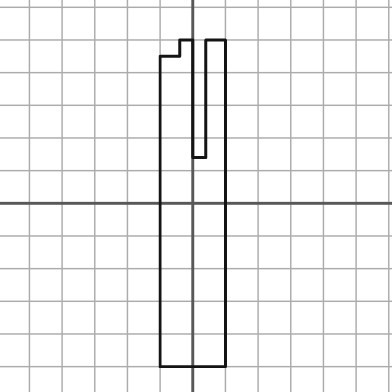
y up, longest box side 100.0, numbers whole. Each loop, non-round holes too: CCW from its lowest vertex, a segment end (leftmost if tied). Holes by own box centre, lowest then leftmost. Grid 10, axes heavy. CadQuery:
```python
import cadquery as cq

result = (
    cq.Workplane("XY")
    .moveTo(-10.0, -50.0)
    .lineTo(10.0, -50.0)
    .lineTo(10.0, 50.0)
    .lineTo(4.0, 50.0)
    .lineTo(4.0, 14.0)
    .lineTo(0.0, 14.0)
    .lineTo(0.0, 50.0)
    .lineTo(-4.0, 50.0)
    .lineTo(-4.0, 45.0)
    .lineTo(-10.0, 45.0)
    .close()
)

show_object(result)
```